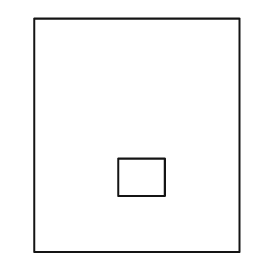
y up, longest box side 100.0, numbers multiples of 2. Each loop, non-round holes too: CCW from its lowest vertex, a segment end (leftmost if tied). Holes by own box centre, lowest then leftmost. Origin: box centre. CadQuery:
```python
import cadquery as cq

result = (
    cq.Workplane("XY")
    .moveTo(-44.0, -50.0)
    .lineTo(44.0, -50.0)
    .lineTo(44.0, 50.0)
    .lineTo(-44.0, 50.0)
    .close()
    .moveTo(-8.0, -26.0)
    .lineTo(12.0, -26.0)
    .lineTo(12.0, -10.0)
    .lineTo(-8.0, -10.0)
    .close()
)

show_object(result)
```